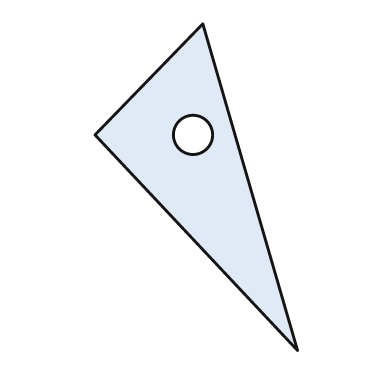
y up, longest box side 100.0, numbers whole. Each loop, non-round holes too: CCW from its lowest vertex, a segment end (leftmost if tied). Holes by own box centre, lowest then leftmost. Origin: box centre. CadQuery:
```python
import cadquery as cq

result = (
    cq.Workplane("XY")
    .moveTo(31.0, -50.0)
    .lineTo(2.0, 50.0)
    .lineTo(-31.0, 16.0)
    .close()
    .moveTo(-1.0, 16.0)
    .circle(6.0)
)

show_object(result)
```